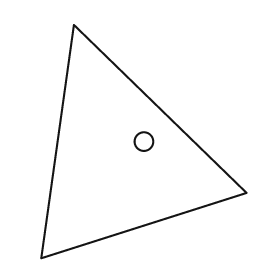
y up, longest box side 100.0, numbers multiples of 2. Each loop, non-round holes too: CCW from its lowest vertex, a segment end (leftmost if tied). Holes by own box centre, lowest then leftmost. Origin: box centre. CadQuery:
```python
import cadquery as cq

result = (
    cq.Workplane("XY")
    .moveTo(-44.0, -50.0)
    .lineTo(44.0, -22.0)
    .lineTo(-30.0, 50.0)
    .close()
    .moveTo(0.0, 0.0)
    .circle(4.0)
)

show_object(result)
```